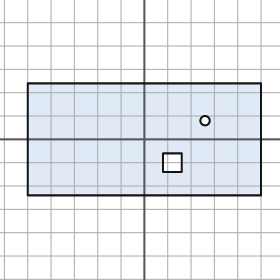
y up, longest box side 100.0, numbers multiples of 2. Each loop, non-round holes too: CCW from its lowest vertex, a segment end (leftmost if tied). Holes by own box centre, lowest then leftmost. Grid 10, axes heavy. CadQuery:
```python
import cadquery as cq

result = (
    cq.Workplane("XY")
    .moveTo(-50.0, -24.0)
    .lineTo(50.0, -24.0)
    .lineTo(50.0, 24.0)
    .lineTo(-50.0, 24.0)
    .close()
    .moveTo(8.0, -14.0)
    .lineTo(16.0, -14.0)
    .lineTo(16.0, -6.0)
    .lineTo(8.0, -6.0)
    .close()
    .moveTo(26.0, 8.0)
    .circle(2.0)
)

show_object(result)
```